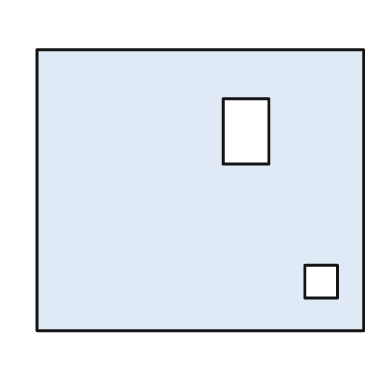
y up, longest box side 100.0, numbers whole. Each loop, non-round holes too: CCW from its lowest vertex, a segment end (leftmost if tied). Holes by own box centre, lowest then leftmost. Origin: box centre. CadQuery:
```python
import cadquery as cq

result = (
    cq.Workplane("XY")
    .moveTo(-50.0, -43.0)
    .lineTo(50.0, -43.0)
    .lineTo(50.0, 43.0)
    .lineTo(-50.0, 43.0)
    .close()
    .moveTo(32.0, -33.0)
    .lineTo(42.0, -33.0)
    .lineTo(42.0, -23.0)
    .lineTo(32.0, -23.0)
    .close()
    .moveTo(7.0, 8.0)
    .lineTo(21.0, 8.0)
    .lineTo(21.0, 28.0)
    .lineTo(7.0, 28.0)
    .close()
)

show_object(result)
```